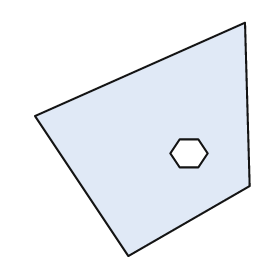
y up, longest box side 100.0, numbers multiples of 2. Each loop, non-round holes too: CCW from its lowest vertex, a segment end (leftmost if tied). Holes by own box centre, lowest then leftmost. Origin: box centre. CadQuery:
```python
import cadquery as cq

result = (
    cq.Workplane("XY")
    .moveTo(-6.0, -50.0)
    .lineTo(46.0, -20.0)
    .lineTo(44.0, 50.0)
    .lineTo(-46.0, 10.0)
    .close()
    .moveTo(16.0, -12.0)
    .lineTo(24.0, -12.0)
    .lineTo(28.0, -6.0)
    .lineTo(24.0, 0.0)
    .lineTo(16.0, 0.0)
    .lineTo(12.0, -6.0)
    .close()
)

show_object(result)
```